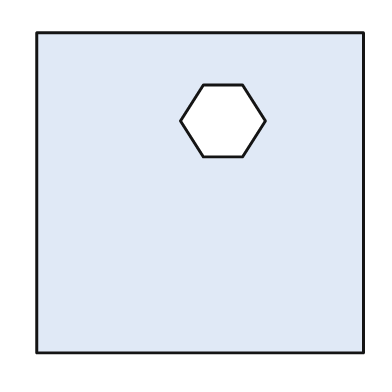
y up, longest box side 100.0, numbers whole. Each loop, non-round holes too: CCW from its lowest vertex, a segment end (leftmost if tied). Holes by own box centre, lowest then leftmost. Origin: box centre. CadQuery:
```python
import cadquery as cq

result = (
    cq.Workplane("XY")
    .moveTo(-50.0, -49.0)
    .lineTo(50.0, -49.0)
    .lineTo(50.0, 49.0)
    .lineTo(-50.0, 49.0)
    .close()
    .moveTo(1.0, 11.0)
    .lineTo(13.0, 11.0)
    .lineTo(20.0, 22.0)
    .lineTo(13.0, 33.0)
    .lineTo(1.0, 33.0)
    .lineTo(-6.0, 22.0)
    .close()
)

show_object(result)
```